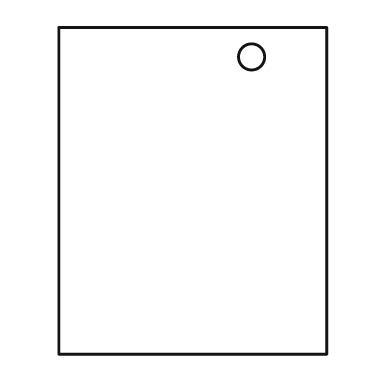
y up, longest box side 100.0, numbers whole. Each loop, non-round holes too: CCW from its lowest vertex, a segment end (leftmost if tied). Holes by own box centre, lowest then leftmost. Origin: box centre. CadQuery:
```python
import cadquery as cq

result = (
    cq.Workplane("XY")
    .moveTo(-41.0, -50.0)
    .lineTo(41.0, -50.0)
    .lineTo(41.0, 50.0)
    .lineTo(-41.0, 50.0)
    .close()
    .moveTo(18.0, 41.0)
    .circle(4.0)
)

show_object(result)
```